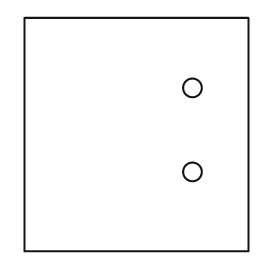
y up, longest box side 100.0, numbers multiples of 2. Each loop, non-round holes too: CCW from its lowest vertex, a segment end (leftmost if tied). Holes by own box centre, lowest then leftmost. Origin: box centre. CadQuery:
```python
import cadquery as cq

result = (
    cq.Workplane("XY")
    .moveTo(-48.0, -50.0)
    .lineTo(48.0, -50.0)
    .lineTo(48.0, 50.0)
    .lineTo(-48.0, 50.0)
    .close()
    .moveTo(24.0, -16.0)
    .circle(4.0)
    .moveTo(24.0, 20.0)
    .circle(4.0)
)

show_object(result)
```